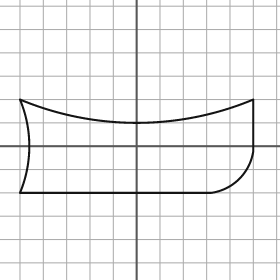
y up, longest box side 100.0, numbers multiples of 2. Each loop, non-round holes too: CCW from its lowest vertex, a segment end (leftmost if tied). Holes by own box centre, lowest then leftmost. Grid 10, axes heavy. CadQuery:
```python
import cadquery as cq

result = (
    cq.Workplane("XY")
    .moveTo(-50.0, -20.0)
    .lineTo(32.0, -20.0)
    .threePointArc((44.0, -14.0), (50.0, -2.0))
    .lineTo(50.0, 20.0)
    .threePointArc((0.0, 10.0), (-50.0, 20.0))
    .threePointArc((-46.0, 0.0), (-50.0, -20.0))
    .close()
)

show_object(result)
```